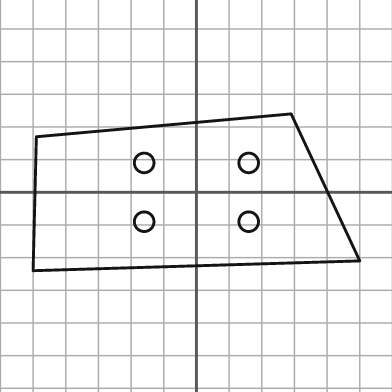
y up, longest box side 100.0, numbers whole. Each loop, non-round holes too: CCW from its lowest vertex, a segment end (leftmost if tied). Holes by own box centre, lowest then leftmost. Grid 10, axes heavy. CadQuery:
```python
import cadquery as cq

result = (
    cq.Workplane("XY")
    .moveTo(-50.0, -24.0)
    .lineTo(50.0, -21.0)
    .lineTo(29.0, 24.0)
    .lineTo(-49.0, 17.0)
    .close()
    .moveTo(-16.0, -9.0)
    .circle(3.0)
    .moveTo(16.0, -9.0)
    .circle(3.0)
    .moveTo(-16.0, 9.0)
    .circle(3.0)
    .moveTo(16.0, 9.0)
    .circle(3.0)
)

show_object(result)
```